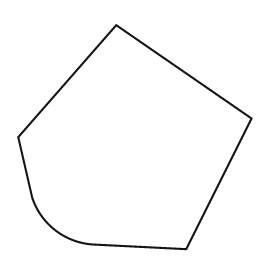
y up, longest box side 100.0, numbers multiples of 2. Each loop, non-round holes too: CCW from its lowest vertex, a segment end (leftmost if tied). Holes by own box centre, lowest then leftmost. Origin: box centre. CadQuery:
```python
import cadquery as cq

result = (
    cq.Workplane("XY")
    .moveTo(22.0, -48.0)
    .lineTo(50.0, 8.0)
    .lineTo(-8.0, 48.0)
    .lineTo(-50.0, 0.0)
    .lineTo(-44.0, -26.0)
    .threePointArc((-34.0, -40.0), (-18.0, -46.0))
    .close()
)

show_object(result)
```